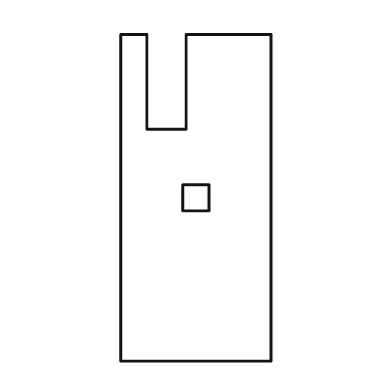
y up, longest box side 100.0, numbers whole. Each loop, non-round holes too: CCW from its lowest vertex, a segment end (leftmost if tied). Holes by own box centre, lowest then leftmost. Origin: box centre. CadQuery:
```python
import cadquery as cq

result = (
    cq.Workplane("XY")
    .moveTo(-23.0, -50.0)
    .lineTo(23.0, -50.0)
    .lineTo(23.0, 50.0)
    .lineTo(-3.0, 50.0)
    .lineTo(-3.0, 21.0)
    .lineTo(-15.0, 21.0)
    .lineTo(-15.0, 50.0)
    .lineTo(-23.0, 50.0)
    .close()
    .moveTo(-4.0, -4.0)
    .lineTo(4.0, -4.0)
    .lineTo(4.0, 4.0)
    .lineTo(-4.0, 4.0)
    .close()
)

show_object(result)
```